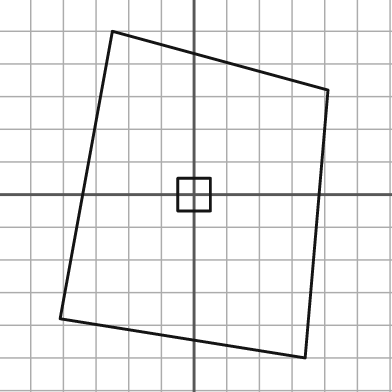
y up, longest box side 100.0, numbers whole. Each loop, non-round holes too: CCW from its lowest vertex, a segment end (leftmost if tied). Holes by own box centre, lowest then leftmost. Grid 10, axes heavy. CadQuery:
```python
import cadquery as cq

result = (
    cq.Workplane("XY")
    .moveTo(34.0, -50.0)
    .lineTo(41.0, 32.0)
    .lineTo(-25.0, 50.0)
    .lineTo(-41.0, -38.0)
    .close()
    .moveTo(-5.0, -5.0)
    .lineTo(5.0, -5.0)
    .lineTo(5.0, 5.0)
    .lineTo(-5.0, 5.0)
    .close()
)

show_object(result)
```